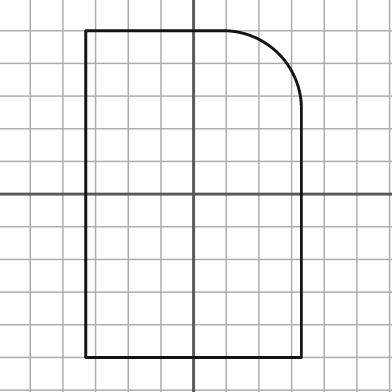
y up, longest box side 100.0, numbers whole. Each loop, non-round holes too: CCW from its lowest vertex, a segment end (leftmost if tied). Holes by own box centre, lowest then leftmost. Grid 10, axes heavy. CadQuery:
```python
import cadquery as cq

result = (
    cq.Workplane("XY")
    .moveTo(-33.0, -50.0)
    .lineTo(33.0, -50.0)
    .lineTo(33.0, 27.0)
    .threePointArc((26.0, 43.0), (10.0, 50.0))
    .lineTo(-33.0, 50.0)
    .close()
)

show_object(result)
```